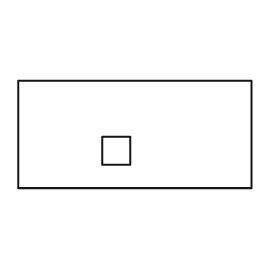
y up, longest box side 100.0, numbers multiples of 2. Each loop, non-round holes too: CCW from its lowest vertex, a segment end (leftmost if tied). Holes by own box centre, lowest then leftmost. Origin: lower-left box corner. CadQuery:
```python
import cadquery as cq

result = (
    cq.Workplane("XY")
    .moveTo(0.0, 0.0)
    .lineTo(100.0, 0.0)
    .lineTo(100.0, 46.0)
    .lineTo(0.0, 46.0)
    .close()
    .moveTo(36.0, 10.0)
    .lineTo(48.0, 10.0)
    .lineTo(48.0, 22.0)
    .lineTo(36.0, 22.0)
    .close()
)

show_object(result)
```